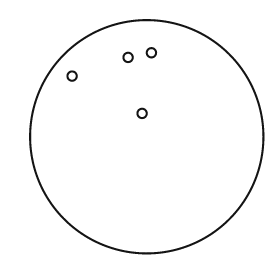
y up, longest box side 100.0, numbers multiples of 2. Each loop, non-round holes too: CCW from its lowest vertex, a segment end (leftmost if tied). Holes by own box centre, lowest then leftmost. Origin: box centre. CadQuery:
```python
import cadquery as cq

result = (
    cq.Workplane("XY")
    .moveTo(0.0, 0.0)
    .circle(50.0)
    .moveTo(-2.0, 10.0)
    .circle(2.0)
    .moveTo(-32.0, 26.0)
    .circle(2.0)
    .moveTo(-8.0, 34.0)
    .circle(2.0)
    .moveTo(2.0, 36.0)
    .circle(2.0)
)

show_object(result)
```